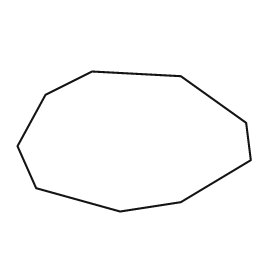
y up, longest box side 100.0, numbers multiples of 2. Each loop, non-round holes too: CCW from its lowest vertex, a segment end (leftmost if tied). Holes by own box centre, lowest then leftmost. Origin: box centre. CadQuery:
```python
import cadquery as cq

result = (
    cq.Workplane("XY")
    .moveTo(-6.0, -30.0)
    .lineTo(20.0, -26.0)
    .lineTo(50.0, -8.0)
    .lineTo(48.0, 8.0)
    .lineTo(20.0, 28.0)
    .lineTo(-18.0, 30.0)
    .lineTo(-38.0, 20.0)
    .lineTo(-50.0, -2.0)
    .lineTo(-42.0, -20.0)
    .close()
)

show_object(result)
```